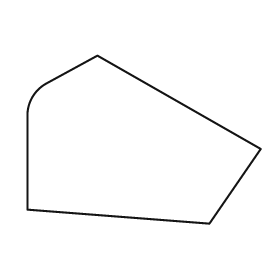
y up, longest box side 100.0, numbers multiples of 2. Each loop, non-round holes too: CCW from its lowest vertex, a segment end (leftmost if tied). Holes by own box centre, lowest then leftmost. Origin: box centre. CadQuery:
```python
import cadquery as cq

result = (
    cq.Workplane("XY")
    .moveTo(28.0, -36.0)
    .lineTo(50.0, -4.0)
    .lineTo(-20.0, 36.0)
    .lineTo(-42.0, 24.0)
    .threePointArc((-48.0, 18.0), (-50.0, 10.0))
    .lineTo(-50.0, -30.0)
    .close()
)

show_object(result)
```